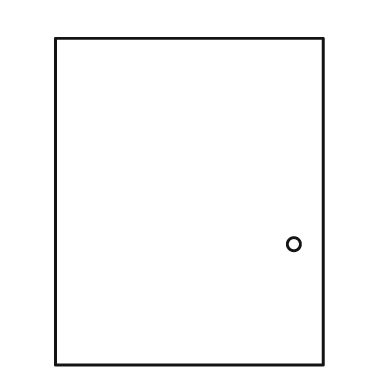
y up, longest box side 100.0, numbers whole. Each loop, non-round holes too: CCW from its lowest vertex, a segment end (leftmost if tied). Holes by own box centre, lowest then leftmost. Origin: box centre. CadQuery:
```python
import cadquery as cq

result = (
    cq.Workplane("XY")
    .moveTo(-41.0, -50.0)
    .lineTo(41.0, -50.0)
    .lineTo(41.0, 50.0)
    .lineTo(-41.0, 50.0)
    .close()
    .moveTo(32.0, -13.0)
    .circle(2.0)
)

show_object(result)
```